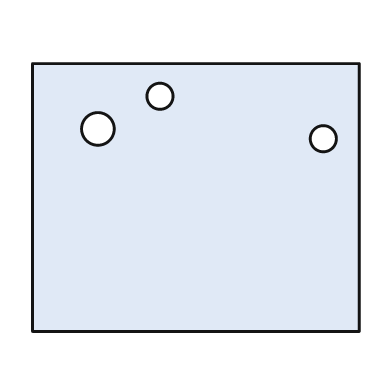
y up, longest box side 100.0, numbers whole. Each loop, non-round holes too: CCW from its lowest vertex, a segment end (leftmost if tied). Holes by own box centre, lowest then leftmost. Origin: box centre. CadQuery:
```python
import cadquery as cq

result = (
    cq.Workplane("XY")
    .moveTo(-50.0, -41.0)
    .lineTo(50.0, -41.0)
    .lineTo(50.0, 41.0)
    .lineTo(-50.0, 41.0)
    .close()
    .moveTo(39.0, 18.0)
    .circle(4.0)
    .moveTo(-30.0, 21.0)
    .circle(5.0)
    .moveTo(-11.0, 31.0)
    .circle(4.0)
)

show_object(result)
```